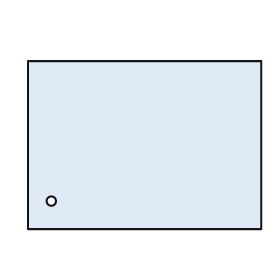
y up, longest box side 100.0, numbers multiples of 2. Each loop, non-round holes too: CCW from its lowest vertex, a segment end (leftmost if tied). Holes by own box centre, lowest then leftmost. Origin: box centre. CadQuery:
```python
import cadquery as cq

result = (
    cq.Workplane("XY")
    .moveTo(-50.0, -36.0)
    .lineTo(50.0, -36.0)
    .lineTo(50.0, 36.0)
    .lineTo(-50.0, 36.0)
    .close()
    .moveTo(-40.0, -24.0)
    .circle(2.0)
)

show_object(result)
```